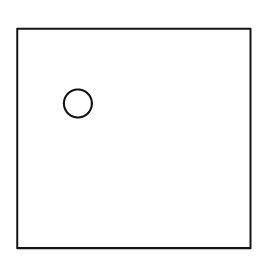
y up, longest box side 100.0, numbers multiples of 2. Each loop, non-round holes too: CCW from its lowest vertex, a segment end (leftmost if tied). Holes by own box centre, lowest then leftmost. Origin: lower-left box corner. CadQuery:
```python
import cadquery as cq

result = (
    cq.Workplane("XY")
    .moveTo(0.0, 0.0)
    .lineTo(100.0, 0.0)
    .lineTo(100.0, 94.0)
    .lineTo(0.0, 94.0)
    .close()
    .moveTo(26.0, 62.0)
    .circle(6.0)
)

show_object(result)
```